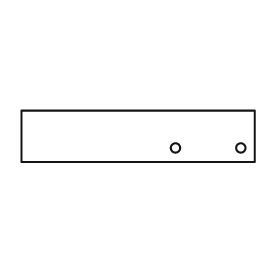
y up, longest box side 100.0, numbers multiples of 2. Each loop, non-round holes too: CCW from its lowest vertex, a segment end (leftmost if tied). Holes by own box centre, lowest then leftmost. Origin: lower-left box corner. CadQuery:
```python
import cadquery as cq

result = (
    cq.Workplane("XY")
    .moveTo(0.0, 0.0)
    .lineTo(100.0, 0.0)
    .lineTo(100.0, 22.0)
    .lineTo(0.0, 22.0)
    .close()
    .moveTo(66.0, 6.0)
    .circle(2.0)
    .moveTo(94.0, 6.0)
    .circle(2.0)
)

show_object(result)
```